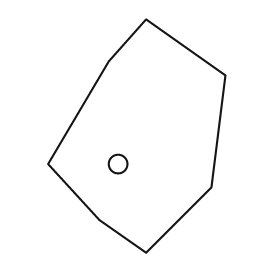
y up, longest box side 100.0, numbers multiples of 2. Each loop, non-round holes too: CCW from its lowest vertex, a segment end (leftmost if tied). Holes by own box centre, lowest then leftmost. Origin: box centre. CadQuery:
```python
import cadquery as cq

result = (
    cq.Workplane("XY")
    .moveTo(4.0, -50.0)
    .lineTo(32.0, -22.0)
    .lineTo(38.0, 26.0)
    .lineTo(4.0, 50.0)
    .lineTo(-12.0, 32.0)
    .lineTo(-38.0, -12.0)
    .lineTo(-16.0, -36.0)
    .close()
    .moveTo(-8.0, -12.0)
    .circle(4.0)
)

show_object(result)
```